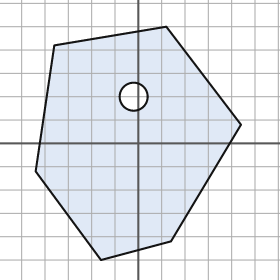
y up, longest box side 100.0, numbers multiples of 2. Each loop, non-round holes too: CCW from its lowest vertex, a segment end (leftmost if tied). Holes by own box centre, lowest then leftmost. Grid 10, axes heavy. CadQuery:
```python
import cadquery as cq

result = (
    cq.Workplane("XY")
    .moveTo(-16.0, -50.0)
    .lineTo(14.0, -42.0)
    .lineTo(44.0, 8.0)
    .lineTo(12.0, 50.0)
    .lineTo(-36.0, 42.0)
    .lineTo(-44.0, -12.0)
    .close()
    .moveTo(-2.0, 20.0)
    .circle(6.0)
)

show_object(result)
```